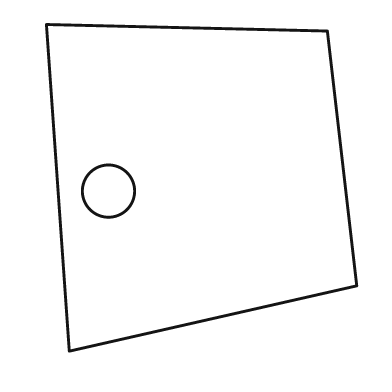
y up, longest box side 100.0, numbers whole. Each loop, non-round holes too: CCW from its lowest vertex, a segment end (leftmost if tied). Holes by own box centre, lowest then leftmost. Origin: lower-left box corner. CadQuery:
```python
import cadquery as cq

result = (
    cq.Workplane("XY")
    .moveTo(7.0, 0.0)
    .lineTo(95.0, 20.0)
    .lineTo(86.0, 98.0)
    .lineTo(0.0, 100.0)
    .close()
    .moveTo(19.0, 49.0)
    .circle(8.0)
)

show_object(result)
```